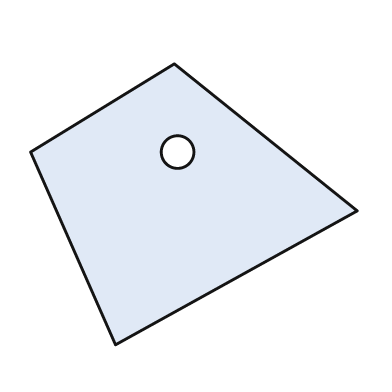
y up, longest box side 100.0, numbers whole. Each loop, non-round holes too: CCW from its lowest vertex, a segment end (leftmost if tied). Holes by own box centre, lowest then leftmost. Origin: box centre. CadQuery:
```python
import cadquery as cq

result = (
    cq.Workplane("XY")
    .moveTo(-24.0, -43.0)
    .lineTo(50.0, -2.0)
    .lineTo(-6.0, 43.0)
    .lineTo(-50.0, 16.0)
    .close()
    .moveTo(-5.0, 16.0)
    .circle(5.0)
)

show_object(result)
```